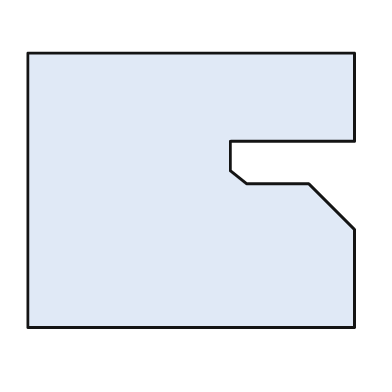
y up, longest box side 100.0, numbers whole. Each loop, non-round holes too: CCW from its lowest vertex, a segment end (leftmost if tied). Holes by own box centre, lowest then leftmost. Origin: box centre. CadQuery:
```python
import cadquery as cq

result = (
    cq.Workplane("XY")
    .moveTo(-50.0, -42.0)
    .lineTo(50.0, -42.0)
    .lineTo(50.0, -12.0)
    .lineTo(36.0, 2.0)
    .lineTo(17.0, 2.0)
    .lineTo(12.0, 6.0)
    .lineTo(12.0, 15.0)
    .lineTo(50.0, 15.0)
    .lineTo(50.0, 42.0)
    .lineTo(-50.0, 42.0)
    .close()
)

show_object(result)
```